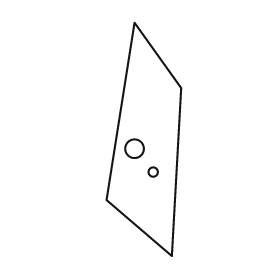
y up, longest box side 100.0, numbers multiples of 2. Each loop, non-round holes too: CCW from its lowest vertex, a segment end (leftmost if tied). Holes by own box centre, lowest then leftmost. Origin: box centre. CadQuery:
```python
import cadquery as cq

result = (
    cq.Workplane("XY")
    .moveTo(12.0, -50.0)
    .lineTo(16.0, 22.0)
    .lineTo(-4.0, 50.0)
    .lineTo(-16.0, -26.0)
    .close()
    .moveTo(4.0, -14.0)
    .circle(2.0)
    .moveTo(-4.0, -4.0)
    .circle(4.0)
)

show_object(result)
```